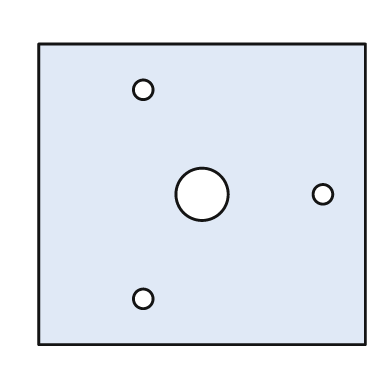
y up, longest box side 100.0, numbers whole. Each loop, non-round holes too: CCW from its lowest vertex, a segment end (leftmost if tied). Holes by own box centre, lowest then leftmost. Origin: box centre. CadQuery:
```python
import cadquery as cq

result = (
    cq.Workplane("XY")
    .moveTo(-50.0, -46.0)
    .lineTo(50.0, -46.0)
    .lineTo(50.0, 46.0)
    .lineTo(-50.0, 46.0)
    .close()
    .moveTo(-18.0, -32.0)
    .circle(3.0)
    .moveTo(0.0, 0.0)
    .circle(8.0)
    .moveTo(37.0, 0.0)
    .circle(3.0)
    .moveTo(-18.0, 32.0)
    .circle(3.0)
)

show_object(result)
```